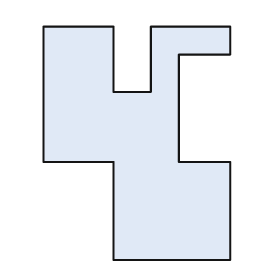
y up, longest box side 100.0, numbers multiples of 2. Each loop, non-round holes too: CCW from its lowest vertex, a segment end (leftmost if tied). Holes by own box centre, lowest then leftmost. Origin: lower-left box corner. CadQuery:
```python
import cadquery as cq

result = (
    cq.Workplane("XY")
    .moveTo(30.0, 0.0)
    .lineTo(80.0, 0.0)
    .lineTo(80.0, 42.0)
    .lineTo(58.0, 42.0)
    .lineTo(58.0, 88.0)
    .lineTo(80.0, 88.0)
    .lineTo(80.0, 100.0)
    .lineTo(46.0, 100.0)
    .lineTo(46.0, 72.0)
    .lineTo(30.0, 72.0)
    .lineTo(30.0, 100.0)
    .lineTo(0.0, 100.0)
    .lineTo(0.0, 42.0)
    .lineTo(30.0, 42.0)
    .close()
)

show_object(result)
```